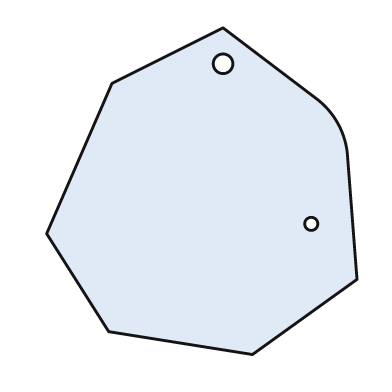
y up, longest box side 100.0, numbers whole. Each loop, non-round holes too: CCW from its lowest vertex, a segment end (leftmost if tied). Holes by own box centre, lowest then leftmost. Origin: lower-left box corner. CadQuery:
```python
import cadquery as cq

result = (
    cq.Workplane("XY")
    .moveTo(63.0, 0.0)
    .lineTo(95.0, 23.0)
    .lineTo(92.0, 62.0)
    .threePointArc((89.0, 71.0), (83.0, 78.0))
    .lineTo(54.0, 100.0)
    .lineTo(20.0, 83.0)
    .lineTo(0.0, 37.0)
    .lineTo(19.0, 7.0)
    .close()
    .moveTo(81.0, 40.0)
    .circle(2.0)
    .moveTo(54.0, 89.0)
    .circle(3.0)
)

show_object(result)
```